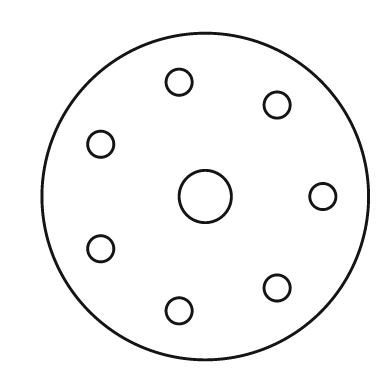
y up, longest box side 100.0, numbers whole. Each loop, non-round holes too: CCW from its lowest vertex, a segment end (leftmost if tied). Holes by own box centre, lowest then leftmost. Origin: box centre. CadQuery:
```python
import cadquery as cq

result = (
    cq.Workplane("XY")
    .moveTo(0.0, 0.0)
    .circle(50.0)
    .moveTo(-8.0, -35.0)
    .circle(4.0)
    .moveTo(22.0, -28.0)
    .circle(4.0)
    .moveTo(-32.0, -16.0)
    .circle(4.0)
    .moveTo(0.0, 0.0)
    .circle(8.0)
    .moveTo(36.0, 0.0)
    .circle(4.0)
    .moveTo(-32.0, 16.0)
    .circle(4.0)
    .moveTo(22.0, 28.0)
    .circle(4.0)
    .moveTo(-8.0, 35.0)
    .circle(4.0)
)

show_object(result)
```